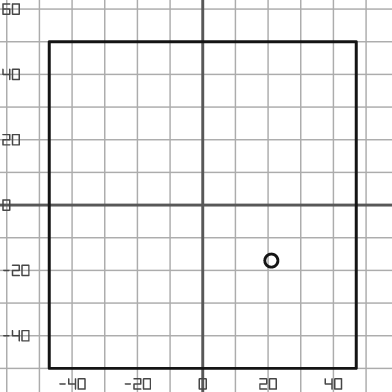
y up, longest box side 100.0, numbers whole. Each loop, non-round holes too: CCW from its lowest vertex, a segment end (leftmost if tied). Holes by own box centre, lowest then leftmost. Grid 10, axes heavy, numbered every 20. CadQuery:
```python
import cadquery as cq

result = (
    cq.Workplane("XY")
    .moveTo(-47.0, -50.0)
    .lineTo(47.0, -50.0)
    .lineTo(47.0, 50.0)
    .lineTo(-47.0, 50.0)
    .close()
    .moveTo(21.0, -17.0)
    .circle(2.0)
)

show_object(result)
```